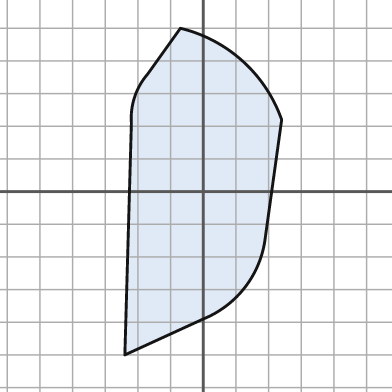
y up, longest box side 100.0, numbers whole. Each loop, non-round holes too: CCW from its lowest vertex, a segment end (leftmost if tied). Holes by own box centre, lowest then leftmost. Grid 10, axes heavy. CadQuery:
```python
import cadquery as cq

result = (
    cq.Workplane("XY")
    .moveTo(-24.0, -50.0)
    .lineTo(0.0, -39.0)
    .threePointArc((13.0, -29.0), (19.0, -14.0))
    .lineTo(24.0, 22.0)
    .threePointArc((12.0, 40.0), (-7.0, 50.0))
    .lineTo(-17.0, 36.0)
    .threePointArc((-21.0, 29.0), (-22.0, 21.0))
    .close()
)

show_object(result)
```